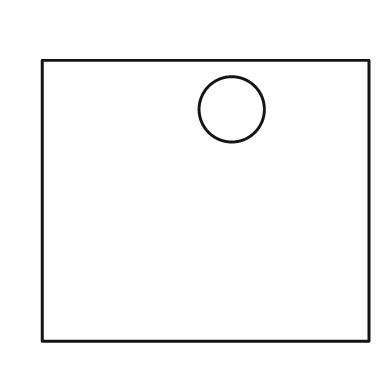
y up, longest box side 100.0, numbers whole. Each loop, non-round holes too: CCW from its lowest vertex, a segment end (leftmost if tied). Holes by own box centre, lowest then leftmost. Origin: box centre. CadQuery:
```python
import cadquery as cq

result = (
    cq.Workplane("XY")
    .moveTo(-50.0, -43.0)
    .lineTo(50.0, -43.0)
    .lineTo(50.0, 43.0)
    .lineTo(-50.0, 43.0)
    .close()
    .moveTo(8.0, 28.0)
    .circle(10.0)
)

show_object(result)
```